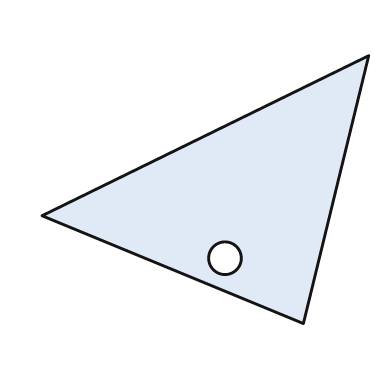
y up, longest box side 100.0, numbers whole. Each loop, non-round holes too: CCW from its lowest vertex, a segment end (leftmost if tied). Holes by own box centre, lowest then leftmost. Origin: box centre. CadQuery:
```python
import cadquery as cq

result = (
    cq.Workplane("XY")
    .moveTo(30.0, -41.0)
    .lineTo(50.0, 41.0)
    .lineTo(-50.0, -8.0)
    .close()
    .moveTo(6.0, -21.0)
    .circle(5.0)
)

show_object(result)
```